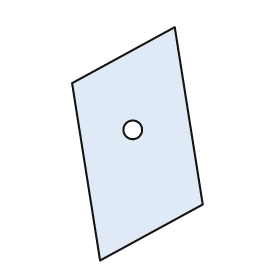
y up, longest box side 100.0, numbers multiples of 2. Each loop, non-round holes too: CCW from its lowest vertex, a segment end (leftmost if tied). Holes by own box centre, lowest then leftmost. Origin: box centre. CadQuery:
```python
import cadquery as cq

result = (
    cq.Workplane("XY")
    .moveTo(-16.0, -50.0)
    .lineTo(28.0, -26.0)
    .lineTo(16.0, 50.0)
    .lineTo(-28.0, 26.0)
    .close()
    .moveTo(-2.0, 6.0)
    .circle(4.0)
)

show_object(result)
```